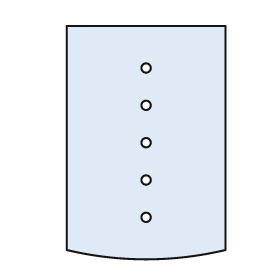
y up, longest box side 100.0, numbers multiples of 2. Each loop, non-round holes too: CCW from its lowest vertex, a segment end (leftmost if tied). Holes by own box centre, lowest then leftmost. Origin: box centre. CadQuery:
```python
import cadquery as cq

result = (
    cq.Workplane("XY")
    .moveTo(-34.0, -46.0)
    .threePointArc((0.0, -50.0), (34.0, -46.0))
    .lineTo(34.0, 50.0)
    .lineTo(-34.0, 50.0)
    .close()
    .moveTo(0.0, -32.0)
    .circle(2.0)
    .moveTo(0.0, -16.0)
    .circle(2.0)
    .moveTo(0.0, 0.0)
    .circle(2.0)
    .moveTo(0.0, 16.0)
    .circle(2.0)
    .moveTo(0.0, 32.0)
    .circle(2.0)
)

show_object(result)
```